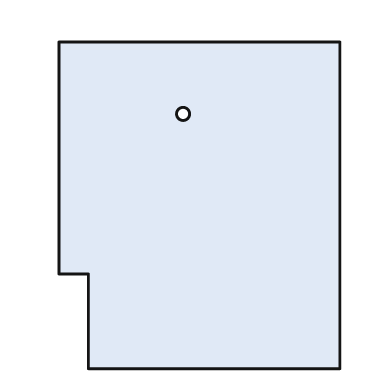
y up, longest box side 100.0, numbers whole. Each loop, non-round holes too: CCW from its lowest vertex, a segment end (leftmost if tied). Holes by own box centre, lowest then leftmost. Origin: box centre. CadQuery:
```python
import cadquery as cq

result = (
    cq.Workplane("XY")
    .moveTo(-34.0, -50.0)
    .lineTo(43.0, -50.0)
    .lineTo(43.0, 50.0)
    .lineTo(-43.0, 50.0)
    .lineTo(-43.0, -21.0)
    .lineTo(-34.0, -21.0)
    .close()
    .moveTo(-5.0, 28.0)
    .circle(2.0)
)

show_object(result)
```